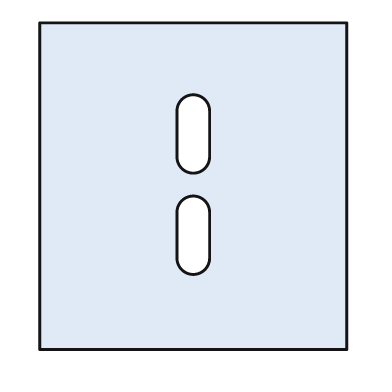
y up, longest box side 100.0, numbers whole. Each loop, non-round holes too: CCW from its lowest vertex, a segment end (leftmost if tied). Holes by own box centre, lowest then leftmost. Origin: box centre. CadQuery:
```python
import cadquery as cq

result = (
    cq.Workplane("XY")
    .moveTo(-47.0, -50.0)
    .lineTo(47.0, -50.0)
    .lineTo(47.0, 50.0)
    .lineTo(-47.0, 50.0)
    .close()
    .moveTo(-5.0, -22.0)
    .threePointArc((0.0, -27.0), (5.0, -22.0))
    .lineTo(5.0, -8.0)
    .threePointArc((0.0, -3.0), (-5.0, -8.0))
    .close()
    .moveTo(-5.0, 9.0)
    .threePointArc((0.0, 4.0), (5.0, 9.0))
    .lineTo(5.0, 23.0)
    .threePointArc((0.0, 28.0), (-5.0, 23.0))
    .close()
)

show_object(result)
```